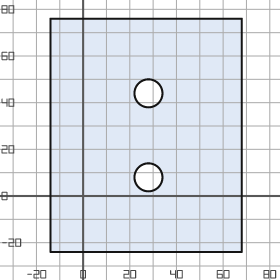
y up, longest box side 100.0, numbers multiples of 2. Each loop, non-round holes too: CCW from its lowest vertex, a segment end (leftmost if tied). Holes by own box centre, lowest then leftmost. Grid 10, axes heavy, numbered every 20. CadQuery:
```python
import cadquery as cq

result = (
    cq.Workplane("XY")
    .moveTo(-14.0, -24.0)
    .lineTo(68.0, -24.0)
    .lineTo(68.0, 76.0)
    .lineTo(-14.0, 76.0)
    .close()
    .moveTo(28.0, 8.0)
    .circle(6.0)
    .moveTo(28.0, 44.0)
    .circle(6.0)
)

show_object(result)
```